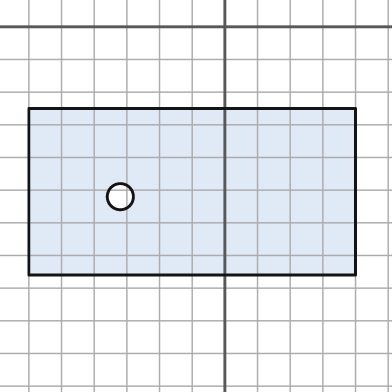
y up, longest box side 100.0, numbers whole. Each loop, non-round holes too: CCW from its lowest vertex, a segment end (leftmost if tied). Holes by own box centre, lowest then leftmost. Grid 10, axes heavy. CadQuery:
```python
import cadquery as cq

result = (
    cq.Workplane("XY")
    .moveTo(-60.0, -76.0)
    .lineTo(40.0, -76.0)
    .lineTo(40.0, -25.0)
    .lineTo(-60.0, -25.0)
    .close()
    .moveTo(-32.0, -52.0)
    .circle(4.0)
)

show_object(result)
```